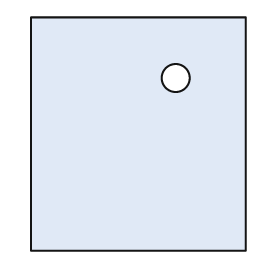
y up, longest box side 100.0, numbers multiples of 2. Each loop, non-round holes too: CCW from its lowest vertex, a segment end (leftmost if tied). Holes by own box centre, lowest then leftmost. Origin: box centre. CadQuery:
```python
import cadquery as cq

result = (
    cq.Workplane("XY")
    .moveTo(-46.0, -50.0)
    .lineTo(46.0, -50.0)
    .lineTo(46.0, 50.0)
    .lineTo(-46.0, 50.0)
    .close()
    .moveTo(16.0, 24.0)
    .circle(6.0)
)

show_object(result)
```